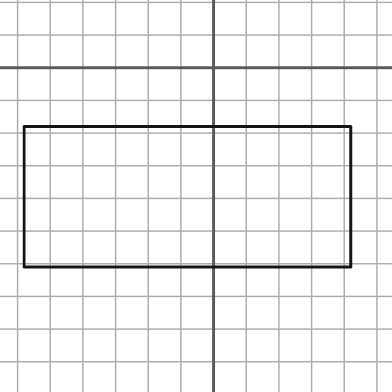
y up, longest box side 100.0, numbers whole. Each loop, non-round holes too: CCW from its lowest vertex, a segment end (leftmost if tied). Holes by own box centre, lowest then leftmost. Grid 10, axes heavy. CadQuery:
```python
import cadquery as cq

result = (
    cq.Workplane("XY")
    .moveTo(-58.0, -61.0)
    .lineTo(42.0, -61.0)
    .lineTo(42.0, -18.0)
    .lineTo(-58.0, -18.0)
    .close()
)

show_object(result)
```